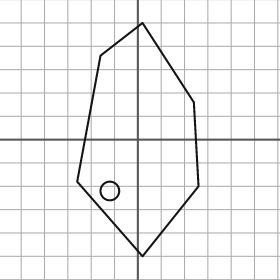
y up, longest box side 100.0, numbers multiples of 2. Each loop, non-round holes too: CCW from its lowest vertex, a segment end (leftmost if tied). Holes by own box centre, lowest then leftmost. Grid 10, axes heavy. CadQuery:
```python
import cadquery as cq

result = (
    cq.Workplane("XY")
    .moveTo(2.0, -50.0)
    .lineTo(26.0, -20.0)
    .lineTo(24.0, 16.0)
    .lineTo(2.0, 50.0)
    .lineTo(-16.0, 36.0)
    .lineTo(-26.0, -18.0)
    .close()
    .moveTo(-12.0, -22.0)
    .circle(4.0)
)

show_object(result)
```